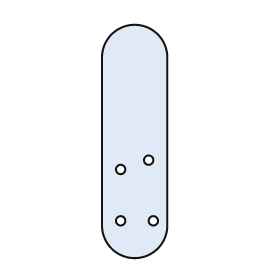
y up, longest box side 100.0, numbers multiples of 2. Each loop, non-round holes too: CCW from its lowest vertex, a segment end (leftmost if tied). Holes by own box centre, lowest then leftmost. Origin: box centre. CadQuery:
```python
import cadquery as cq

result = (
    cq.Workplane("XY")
    .moveTo(-14.0, -36.0)
    .threePointArc((0.0, -50.0), (14.0, -36.0))
    .lineTo(14.0, 36.0)
    .threePointArc((0.0, 50.0), (-14.0, 36.0))
    .close()
    .moveTo(-6.0, -34.0)
    .circle(2.0)
    .moveTo(8.0, -34.0)
    .circle(2.0)
    .moveTo(-6.0, -12.0)
    .circle(2.0)
    .moveTo(6.0, -8.0)
    .circle(2.0)
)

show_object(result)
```